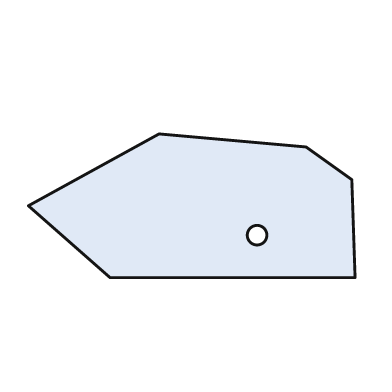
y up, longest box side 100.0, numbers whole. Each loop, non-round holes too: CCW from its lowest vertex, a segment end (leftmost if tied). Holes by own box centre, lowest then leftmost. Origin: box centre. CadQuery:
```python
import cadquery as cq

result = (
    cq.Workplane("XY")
    .moveTo(-25.0, -22.0)
    .lineTo(50.0, -22.0)
    .lineTo(49.0, 8.0)
    .lineTo(35.0, 18.0)
    .lineTo(-10.0, 22.0)
    .lineTo(-50.0, 0.0)
    .close()
    .moveTo(20.0, -9.0)
    .circle(3.0)
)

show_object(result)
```